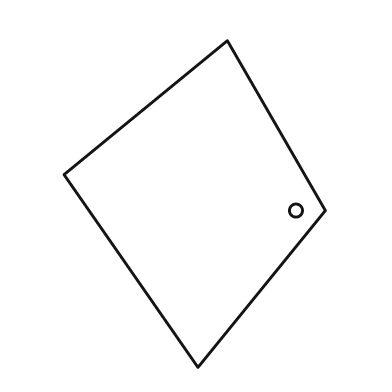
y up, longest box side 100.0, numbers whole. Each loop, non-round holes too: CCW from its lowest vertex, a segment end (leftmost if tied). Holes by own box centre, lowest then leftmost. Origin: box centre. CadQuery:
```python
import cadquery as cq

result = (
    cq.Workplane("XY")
    .moveTo(1.0, -50.0)
    .lineTo(40.0, -2.0)
    .lineTo(10.0, 50.0)
    .lineTo(-40.0, 9.0)
    .close()
    .moveTo(31.0, -2.0)
    .circle(2.0)
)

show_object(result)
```